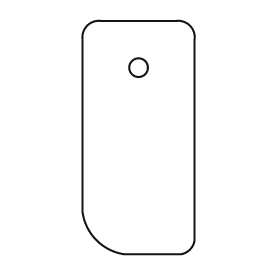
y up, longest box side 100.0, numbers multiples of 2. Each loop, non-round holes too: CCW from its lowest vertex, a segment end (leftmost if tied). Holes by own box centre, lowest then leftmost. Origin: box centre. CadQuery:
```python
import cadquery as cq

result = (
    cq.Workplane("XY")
    .moveTo(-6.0, -50.0)
    .lineTo(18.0, -50.0)
    .threePointArc((22.0, -48.0), (24.0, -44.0))
    .lineTo(24.0, 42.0)
    .threePointArc((22.0, 48.0), (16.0, 50.0))
    .lineTo(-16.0, 50.0)
    .threePointArc((-22.0, 48.0), (-24.0, 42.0))
    .lineTo(-24.0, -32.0)
    .threePointArc((-18.0, -44.0), (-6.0, -50.0))
    .close()
    .moveTo(0.0, 30.0)
    .circle(4.0)
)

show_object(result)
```